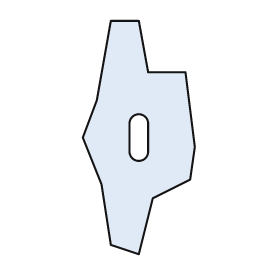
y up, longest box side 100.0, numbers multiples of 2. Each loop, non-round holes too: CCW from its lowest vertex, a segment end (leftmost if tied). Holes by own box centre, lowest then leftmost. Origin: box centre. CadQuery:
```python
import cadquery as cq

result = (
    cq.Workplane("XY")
    .moveTo(0.0, -50.0)
    .lineTo(6.0, -26.0)
    .lineTo(22.0, -18.0)
    .lineTo(24.0, -4.0)
    .lineTo(20.0, 28.0)
    .lineTo(4.0, 28.0)
    .lineTo(0.0, 50.0)
    .lineTo(-12.0, 50.0)
    .lineTo(-18.0, 16.0)
    .lineTo(-24.0, 0.0)
    .lineTo(-16.0, -20.0)
    .lineTo(-12.0, -46.0)
    .close()
    .moveTo(-4.0, -6.0)
    .threePointArc((0.0, -10.0), (4.0, -6.0))
    .lineTo(4.0, 6.0)
    .threePointArc((0.0, 10.0), (-4.0, 6.0))
    .close()
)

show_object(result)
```